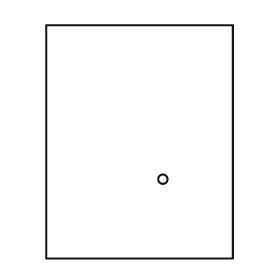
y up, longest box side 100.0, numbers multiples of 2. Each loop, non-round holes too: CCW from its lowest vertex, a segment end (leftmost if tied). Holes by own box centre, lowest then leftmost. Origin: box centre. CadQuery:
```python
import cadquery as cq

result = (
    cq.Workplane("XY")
    .moveTo(-40.0, -50.0)
    .lineTo(40.0, -50.0)
    .lineTo(40.0, 50.0)
    .lineTo(-40.0, 50.0)
    .close()
    .moveTo(10.0, -16.0)
    .circle(2.0)
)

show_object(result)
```